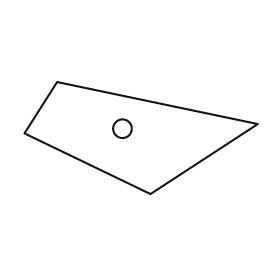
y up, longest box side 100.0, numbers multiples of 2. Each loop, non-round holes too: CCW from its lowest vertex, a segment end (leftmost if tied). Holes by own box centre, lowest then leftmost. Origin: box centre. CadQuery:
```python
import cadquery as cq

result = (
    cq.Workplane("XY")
    .moveTo(4.0, -24.0)
    .lineTo(50.0, 6.0)
    .lineTo(-36.0, 24.0)
    .lineTo(-50.0, 2.0)
    .close()
    .moveTo(-8.0, 4.0)
    .circle(4.0)
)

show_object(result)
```